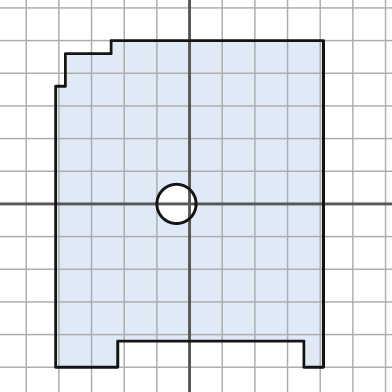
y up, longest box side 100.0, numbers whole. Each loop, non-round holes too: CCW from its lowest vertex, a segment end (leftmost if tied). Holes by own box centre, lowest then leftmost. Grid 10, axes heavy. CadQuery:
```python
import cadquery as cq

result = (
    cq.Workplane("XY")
    .moveTo(-41.0, -50.0)
    .lineTo(-22.0, -50.0)
    .lineTo(-22.0, -42.0)
    .lineTo(35.0, -42.0)
    .lineTo(35.0, -50.0)
    .lineTo(41.0, -50.0)
    .lineTo(41.0, 50.0)
    .lineTo(-24.0, 50.0)
    .lineTo(-24.0, 46.0)
    .lineTo(-38.0, 46.0)
    .lineTo(-38.0, 36.0)
    .lineTo(-41.0, 36.0)
    .close()
    .moveTo(-4.0, 0.0)
    .circle(6.0)
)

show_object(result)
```